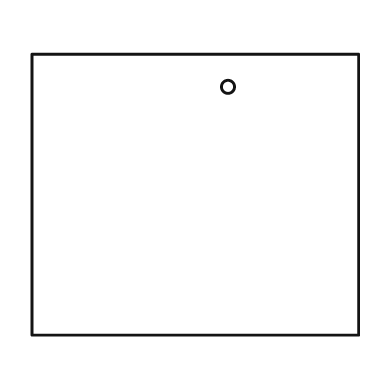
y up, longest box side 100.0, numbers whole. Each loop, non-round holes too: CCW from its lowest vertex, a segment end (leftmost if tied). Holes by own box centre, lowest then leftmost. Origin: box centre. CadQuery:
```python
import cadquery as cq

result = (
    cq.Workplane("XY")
    .moveTo(-50.0, -43.0)
    .lineTo(50.0, -43.0)
    .lineTo(50.0, 43.0)
    .lineTo(-50.0, 43.0)
    .close()
    .moveTo(10.0, 33.0)
    .circle(2.0)
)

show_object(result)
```